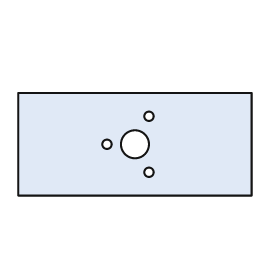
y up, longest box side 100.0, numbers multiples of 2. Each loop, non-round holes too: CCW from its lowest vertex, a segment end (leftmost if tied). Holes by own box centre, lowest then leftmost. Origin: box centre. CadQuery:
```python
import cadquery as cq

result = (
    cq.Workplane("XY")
    .moveTo(-50.0, -22.0)
    .lineTo(50.0, -22.0)
    .lineTo(50.0, 22.0)
    .lineTo(-50.0, 22.0)
    .close()
    .moveTo(6.0, -12.0)
    .circle(2.0)
    .moveTo(-12.0, 0.0)
    .circle(2.0)
    .moveTo(0.0, 0.0)
    .circle(6.0)
    .moveTo(6.0, 12.0)
    .circle(2.0)
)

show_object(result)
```